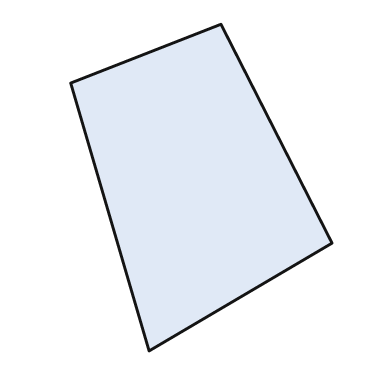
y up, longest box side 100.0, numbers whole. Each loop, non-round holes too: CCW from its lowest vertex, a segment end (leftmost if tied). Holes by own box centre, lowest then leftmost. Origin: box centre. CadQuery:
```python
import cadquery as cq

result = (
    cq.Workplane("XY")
    .moveTo(-16.0, -50.0)
    .lineTo(40.0, -17.0)
    .lineTo(6.0, 50.0)
    .lineTo(-40.0, 32.0)
    .close()
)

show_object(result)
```